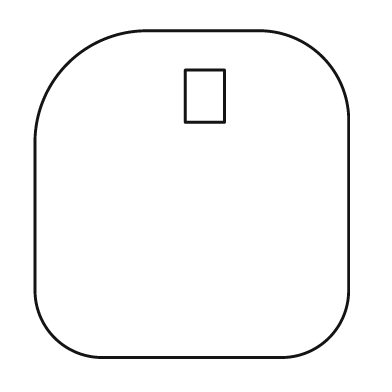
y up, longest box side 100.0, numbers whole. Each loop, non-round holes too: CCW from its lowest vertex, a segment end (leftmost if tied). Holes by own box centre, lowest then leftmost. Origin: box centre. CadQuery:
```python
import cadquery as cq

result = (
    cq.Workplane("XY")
    .moveTo(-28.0, -50.0)
    .lineTo(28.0, -50.0)
    .threePointArc((42.0, -44.0), (48.0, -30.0))
    .lineTo(48.0, 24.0)
    .threePointArc((40.0, 42.0), (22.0, 50.0))
    .lineTo(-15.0, 50.0)
    .threePointArc((-38.0, 40.0), (-48.0, 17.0))
    .lineTo(-48.0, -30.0)
    .threePointArc((-42.0, -44.0), (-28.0, -50.0))
    .close()
    .moveTo(-2.0, 22.0)
    .lineTo(10.0, 22.0)
    .lineTo(10.0, 38.0)
    .lineTo(-2.0, 38.0)
    .close()
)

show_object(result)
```